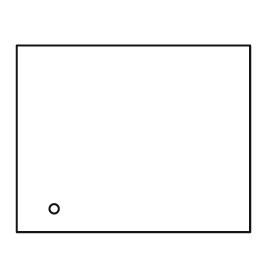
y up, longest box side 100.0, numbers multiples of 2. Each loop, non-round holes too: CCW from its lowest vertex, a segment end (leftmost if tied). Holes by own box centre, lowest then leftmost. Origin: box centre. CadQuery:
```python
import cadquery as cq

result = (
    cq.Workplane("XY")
    .moveTo(-50.0, -40.0)
    .lineTo(50.0, -40.0)
    .lineTo(50.0, 40.0)
    .lineTo(-50.0, 40.0)
    .close()
    .moveTo(-34.0, -30.0)
    .circle(2.0)
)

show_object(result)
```